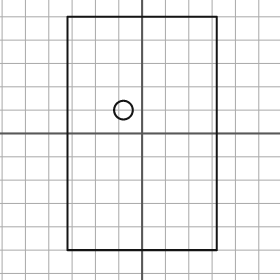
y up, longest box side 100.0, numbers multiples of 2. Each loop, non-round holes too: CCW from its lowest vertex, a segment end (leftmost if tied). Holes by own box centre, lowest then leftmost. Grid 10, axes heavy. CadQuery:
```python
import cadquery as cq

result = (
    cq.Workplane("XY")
    .moveTo(-32.0, -50.0)
    .lineTo(32.0, -50.0)
    .lineTo(32.0, 50.0)
    .lineTo(-32.0, 50.0)
    .close()
    .moveTo(-8.0, 10.0)
    .circle(4.0)
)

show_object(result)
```